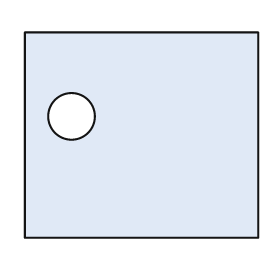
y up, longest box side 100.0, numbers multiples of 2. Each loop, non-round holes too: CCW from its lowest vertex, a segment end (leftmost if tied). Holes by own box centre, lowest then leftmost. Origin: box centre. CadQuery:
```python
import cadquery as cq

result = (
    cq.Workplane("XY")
    .moveTo(-50.0, -44.0)
    .lineTo(50.0, -44.0)
    .lineTo(50.0, 44.0)
    .lineTo(-50.0, 44.0)
    .close()
    .moveTo(-30.0, 8.0)
    .circle(10.0)
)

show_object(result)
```